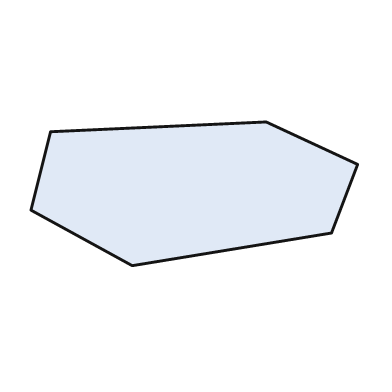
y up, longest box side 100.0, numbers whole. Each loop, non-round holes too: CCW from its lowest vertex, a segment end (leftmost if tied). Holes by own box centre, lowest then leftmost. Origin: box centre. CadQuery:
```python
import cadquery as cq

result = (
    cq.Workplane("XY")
    .moveTo(-19.0, -22.0)
    .lineTo(42.0, -12.0)
    .lineTo(50.0, 9.0)
    .lineTo(22.0, 22.0)
    .lineTo(-44.0, 19.0)
    .lineTo(-50.0, -5.0)
    .close()
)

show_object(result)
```